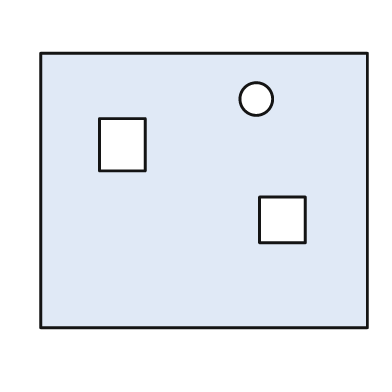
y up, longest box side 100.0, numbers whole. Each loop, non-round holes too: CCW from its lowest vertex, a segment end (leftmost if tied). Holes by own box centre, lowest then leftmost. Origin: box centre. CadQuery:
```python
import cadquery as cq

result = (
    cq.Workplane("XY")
    .moveTo(-50.0, -42.0)
    .lineTo(50.0, -42.0)
    .lineTo(50.0, 42.0)
    .lineTo(-50.0, 42.0)
    .close()
    .moveTo(17.0, -16.0)
    .lineTo(31.0, -16.0)
    .lineTo(31.0, -2.0)
    .lineTo(17.0, -2.0)
    .close()
    .moveTo(-32.0, 6.0)
    .lineTo(-18.0, 6.0)
    .lineTo(-18.0, 22.0)
    .lineTo(-32.0, 22.0)
    .close()
    .moveTo(16.0, 28.0)
    .circle(5.0)
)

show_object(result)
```